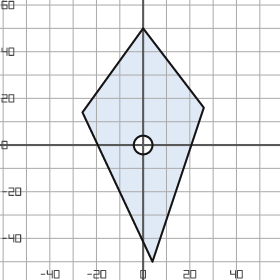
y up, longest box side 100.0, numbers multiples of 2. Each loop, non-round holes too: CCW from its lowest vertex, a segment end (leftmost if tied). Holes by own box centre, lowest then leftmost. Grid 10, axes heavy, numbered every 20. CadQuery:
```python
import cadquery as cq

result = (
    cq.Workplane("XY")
    .moveTo(4.0, -50.0)
    .lineTo(26.0, 16.0)
    .lineTo(0.0, 50.0)
    .lineTo(-26.0, 14.0)
    .close()
    .moveTo(0.0, 0.0)
    .circle(4.0)
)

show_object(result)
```